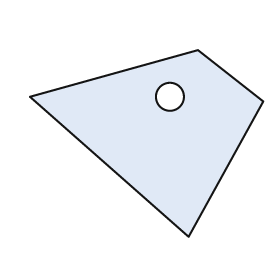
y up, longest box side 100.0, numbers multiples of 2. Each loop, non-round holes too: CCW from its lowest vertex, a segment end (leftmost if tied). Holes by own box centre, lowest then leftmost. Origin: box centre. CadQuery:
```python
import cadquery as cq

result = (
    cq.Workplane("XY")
    .moveTo(18.0, -40.0)
    .lineTo(50.0, 18.0)
    .lineTo(22.0, 40.0)
    .lineTo(-50.0, 20.0)
    .close()
    .moveTo(10.0, 20.0)
    .circle(6.0)
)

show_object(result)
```